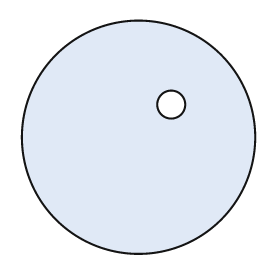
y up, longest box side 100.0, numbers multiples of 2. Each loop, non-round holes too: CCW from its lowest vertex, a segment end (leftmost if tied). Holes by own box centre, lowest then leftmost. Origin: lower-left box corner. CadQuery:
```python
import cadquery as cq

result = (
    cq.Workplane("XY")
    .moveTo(50.0, 50.0)
    .circle(50.0)
    .moveTo(64.0, 64.0)
    .circle(6.0)
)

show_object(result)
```